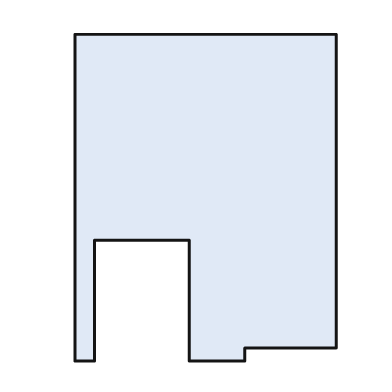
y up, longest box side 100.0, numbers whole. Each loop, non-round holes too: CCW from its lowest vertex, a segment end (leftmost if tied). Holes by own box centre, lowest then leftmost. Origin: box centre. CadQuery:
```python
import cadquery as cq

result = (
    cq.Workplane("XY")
    .moveTo(-40.0, -50.0)
    .lineTo(-34.0, -50.0)
    .lineTo(-34.0, -13.0)
    .lineTo(-5.0, -13.0)
    .lineTo(-5.0, -50.0)
    .lineTo(12.0, -50.0)
    .lineTo(12.0, -46.0)
    .lineTo(40.0, -46.0)
    .lineTo(40.0, 50.0)
    .lineTo(-40.0, 50.0)
    .close()
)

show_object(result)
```